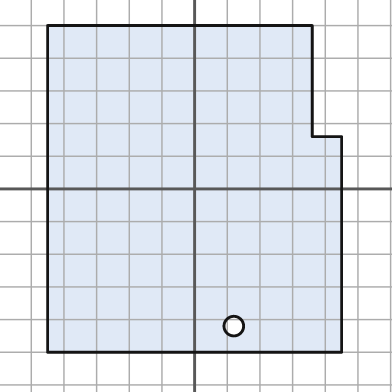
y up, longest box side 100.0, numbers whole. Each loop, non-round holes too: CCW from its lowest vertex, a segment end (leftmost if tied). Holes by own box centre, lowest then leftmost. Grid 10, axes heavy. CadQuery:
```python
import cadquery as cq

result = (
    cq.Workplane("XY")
    .moveTo(-45.0, -50.0)
    .lineTo(45.0, -50.0)
    .lineTo(45.0, 16.0)
    .lineTo(36.0, 16.0)
    .lineTo(36.0, 50.0)
    .lineTo(-45.0, 50.0)
    .close()
    .moveTo(12.0, -42.0)
    .circle(3.0)
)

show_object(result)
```